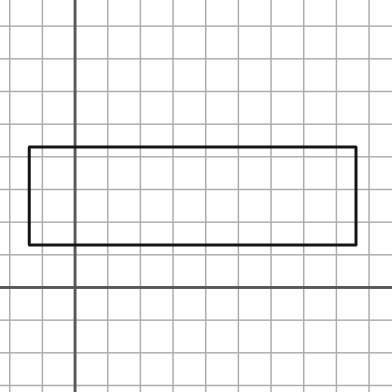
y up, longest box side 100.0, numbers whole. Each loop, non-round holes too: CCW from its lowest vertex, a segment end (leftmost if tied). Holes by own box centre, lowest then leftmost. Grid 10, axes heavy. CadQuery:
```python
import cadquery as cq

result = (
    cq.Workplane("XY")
    .moveTo(-14.0, 13.0)
    .lineTo(86.0, 13.0)
    .lineTo(86.0, 43.0)
    .lineTo(-14.0, 43.0)
    .close()
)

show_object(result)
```